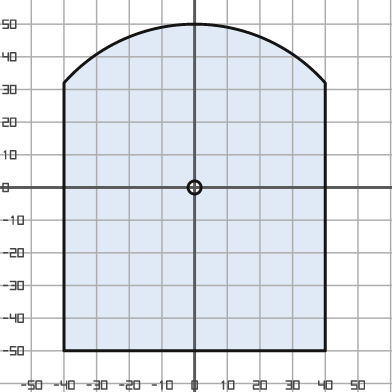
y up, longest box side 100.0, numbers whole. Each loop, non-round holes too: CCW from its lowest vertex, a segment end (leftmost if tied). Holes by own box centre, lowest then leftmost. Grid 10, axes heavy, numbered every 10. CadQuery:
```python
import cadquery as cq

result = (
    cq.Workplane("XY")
    .moveTo(-40.0, -50.0)
    .lineTo(40.0, -50.0)
    .lineTo(40.0, 32.0)
    .threePointArc((0.0, 50.0), (-40.0, 32.0))
    .close()
    .moveTo(0.0, 0.0)
    .circle(2.0)
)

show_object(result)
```